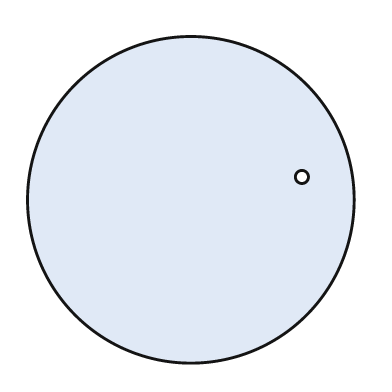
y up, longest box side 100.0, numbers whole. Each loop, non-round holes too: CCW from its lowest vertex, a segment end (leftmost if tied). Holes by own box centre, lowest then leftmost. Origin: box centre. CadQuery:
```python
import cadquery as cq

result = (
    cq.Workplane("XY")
    .moveTo(0.0, 0.0)
    .circle(50.0)
    .moveTo(34.0, 7.0)
    .circle(2.0)
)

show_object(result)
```